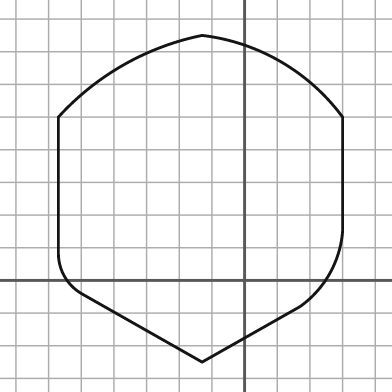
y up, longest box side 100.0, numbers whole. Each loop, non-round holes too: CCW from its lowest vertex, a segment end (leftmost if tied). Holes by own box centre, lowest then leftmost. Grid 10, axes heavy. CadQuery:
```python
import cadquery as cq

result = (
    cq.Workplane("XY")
    .moveTo(-13.0, -25.0)
    .lineTo(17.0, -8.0)
    .threePointArc((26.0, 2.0), (30.0, 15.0))
    .lineTo(30.0, 50.0)
    .threePointArc((11.0, 67.0), (-13.0, 75.0))
    .threePointArc((-37.0, 66.0), (-57.0, 50.0))
    .lineTo(-57.0, 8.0)
    .threePointArc((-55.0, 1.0), (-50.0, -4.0))
    .close()
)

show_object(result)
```